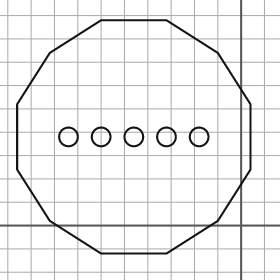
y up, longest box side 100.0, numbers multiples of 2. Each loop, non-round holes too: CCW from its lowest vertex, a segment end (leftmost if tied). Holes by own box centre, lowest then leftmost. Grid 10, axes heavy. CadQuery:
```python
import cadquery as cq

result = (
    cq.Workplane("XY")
    .moveTo(-60.0, -12.0)
    .lineTo(-32.0, -12.0)
    .lineTo(-10.0, 2.0)
    .lineTo(4.0, 24.0)
    .lineTo(4.0, 52.0)
    .lineTo(-10.0, 74.0)
    .lineTo(-32.0, 88.0)
    .lineTo(-60.0, 88.0)
    .lineTo(-82.0, 74.0)
    .lineTo(-96.0, 52.0)
    .lineTo(-96.0, 24.0)
    .lineTo(-82.0, 2.0)
    .close()
    .moveTo(-74.0, 38.0)
    .circle(4.0)
    .moveTo(-60.0, 38.0)
    .circle(4.0)
    .moveTo(-46.0, 38.0)
    .circle(4.0)
    .moveTo(-32.0, 38.0)
    .circle(4.0)
    .moveTo(-18.0, 38.0)
    .circle(4.0)
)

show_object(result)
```